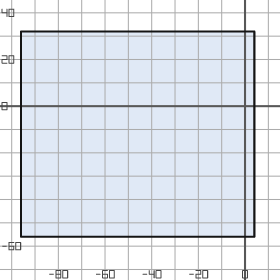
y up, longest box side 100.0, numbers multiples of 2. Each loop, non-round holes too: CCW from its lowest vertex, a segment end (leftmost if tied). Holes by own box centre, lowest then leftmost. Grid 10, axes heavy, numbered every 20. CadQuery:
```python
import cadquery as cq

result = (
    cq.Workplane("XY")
    .moveTo(-96.0, -56.0)
    .lineTo(4.0, -56.0)
    .lineTo(4.0, 32.0)
    .lineTo(-96.0, 32.0)
    .close()
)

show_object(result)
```